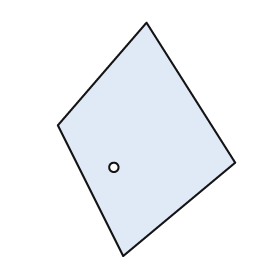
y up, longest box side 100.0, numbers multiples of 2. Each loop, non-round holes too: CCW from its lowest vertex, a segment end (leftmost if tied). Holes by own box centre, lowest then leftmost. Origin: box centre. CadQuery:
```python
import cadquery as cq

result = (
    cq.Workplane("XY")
    .moveTo(-10.0, -50.0)
    .lineTo(38.0, -10.0)
    .lineTo(0.0, 50.0)
    .lineTo(-38.0, 6.0)
    .close()
    .moveTo(-14.0, -12.0)
    .circle(2.0)
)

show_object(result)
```